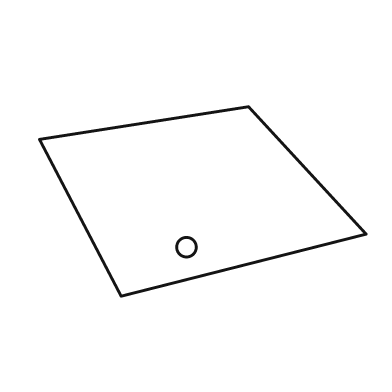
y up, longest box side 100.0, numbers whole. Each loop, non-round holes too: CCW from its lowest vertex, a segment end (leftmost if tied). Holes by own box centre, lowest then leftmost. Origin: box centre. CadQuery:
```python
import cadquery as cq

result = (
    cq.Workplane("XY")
    .moveTo(-25.0, -29.0)
    .lineTo(50.0, -10.0)
    .lineTo(14.0, 29.0)
    .lineTo(-50.0, 19.0)
    .close()
    .moveTo(-5.0, -14.0)
    .circle(3.0)
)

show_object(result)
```